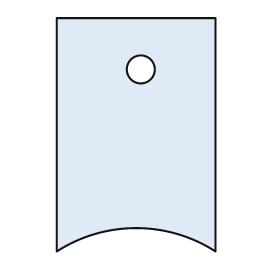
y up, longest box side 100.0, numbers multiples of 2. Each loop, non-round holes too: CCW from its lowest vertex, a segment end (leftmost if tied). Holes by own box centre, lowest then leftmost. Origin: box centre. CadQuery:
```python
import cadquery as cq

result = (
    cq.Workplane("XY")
    .moveTo(-34.0, -50.0)
    .threePointArc((0.0, -40.0), (34.0, -50.0))
    .lineTo(34.0, 50.0)
    .lineTo(-34.0, 50.0)
    .close()
    .moveTo(2.0, 28.0)
    .circle(6.0)
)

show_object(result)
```